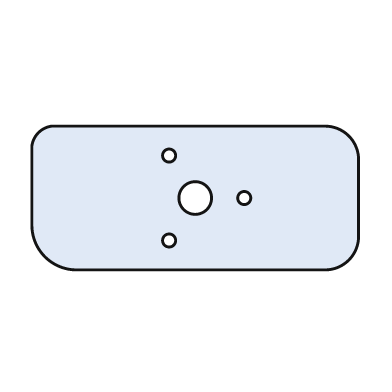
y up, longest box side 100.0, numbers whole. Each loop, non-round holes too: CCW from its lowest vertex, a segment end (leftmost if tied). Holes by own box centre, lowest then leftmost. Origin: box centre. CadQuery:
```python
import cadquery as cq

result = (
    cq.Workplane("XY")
    .moveTo(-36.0, -22.0)
    .lineTo(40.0, -22.0)
    .threePointArc((47.0, -19.0), (50.0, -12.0))
    .lineTo(50.0, 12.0)
    .threePointArc((47.0, 19.0), (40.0, 22.0))
    .lineTo(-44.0, 22.0)
    .threePointArc((-48.0, 20.0), (-50.0, 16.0))
    .lineTo(-50.0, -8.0)
    .threePointArc((-46.0, -18.0), (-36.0, -22.0))
    .close()
    .moveTo(-8.0, -13.0)
    .circle(2.0)
    .moveTo(0.0, 0.0)
    .circle(5.0)
    .moveTo(15.0, 0.0)
    .circle(2.0)
    .moveTo(-8.0, 13.0)
    .circle(2.0)
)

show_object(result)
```